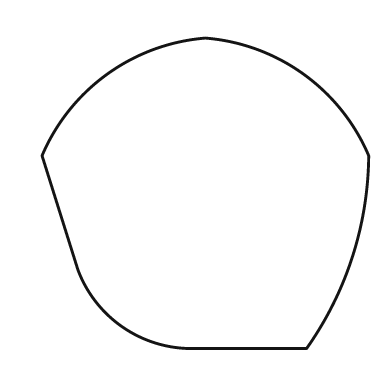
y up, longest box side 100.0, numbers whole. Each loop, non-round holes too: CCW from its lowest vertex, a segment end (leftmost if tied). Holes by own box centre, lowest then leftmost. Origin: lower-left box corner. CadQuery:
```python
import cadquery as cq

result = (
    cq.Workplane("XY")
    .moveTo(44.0, 0.0)
    .lineTo(81.0, 0.0)
    .threePointArc((95.0, 28.0), (100.0, 59.0))
    .threePointArc((80.0, 84.0), (50.0, 95.0))
    .threePointArc((20.0, 84.0), (0.0, 59.0))
    .lineTo(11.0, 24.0)
    .threePointArc((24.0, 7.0), (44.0, 0.0))
    .close()
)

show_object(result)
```